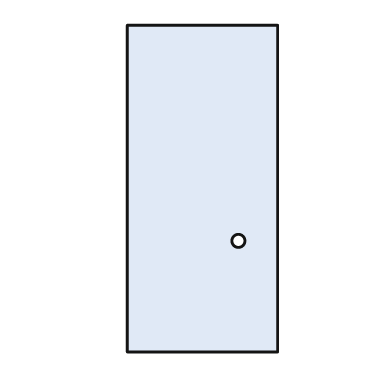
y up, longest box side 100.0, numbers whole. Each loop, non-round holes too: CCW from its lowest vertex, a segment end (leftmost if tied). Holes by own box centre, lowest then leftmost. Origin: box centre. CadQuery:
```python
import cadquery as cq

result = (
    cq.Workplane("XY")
    .moveTo(-23.0, -50.0)
    .lineTo(23.0, -50.0)
    .lineTo(23.0, 50.0)
    .lineTo(-23.0, 50.0)
    .close()
    .moveTo(11.0, -16.0)
    .circle(2.0)
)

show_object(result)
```